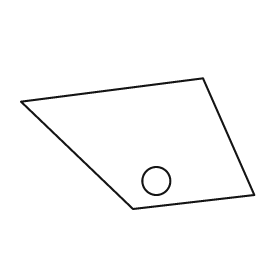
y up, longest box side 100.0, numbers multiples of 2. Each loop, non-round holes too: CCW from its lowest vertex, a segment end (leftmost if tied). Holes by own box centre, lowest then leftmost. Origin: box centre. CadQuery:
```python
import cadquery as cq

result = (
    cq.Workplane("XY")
    .moveTo(-2.0, -28.0)
    .lineTo(50.0, -22.0)
    .lineTo(28.0, 28.0)
    .lineTo(-50.0, 18.0)
    .close()
    .moveTo(8.0, -16.0)
    .circle(6.0)
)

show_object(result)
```